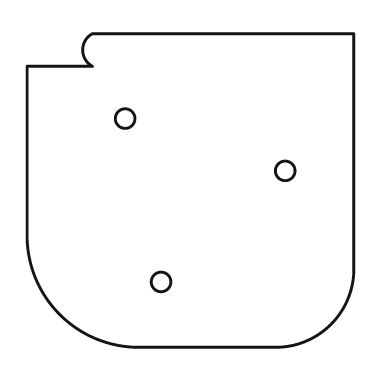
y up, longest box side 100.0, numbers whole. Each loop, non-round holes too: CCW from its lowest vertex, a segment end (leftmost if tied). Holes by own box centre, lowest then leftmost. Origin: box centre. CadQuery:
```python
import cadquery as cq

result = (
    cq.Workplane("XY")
    .moveTo(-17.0, -48.0)
    .lineTo(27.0, -48.0)
    .threePointArc((43.0, -41.0), (50.0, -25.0))
    .lineTo(50.0, 48.0)
    .lineTo(-30.0, 48.0)
    .threePointArc((-33.0, 43.0), (-30.0, 38.0))
    .lineTo(-50.0, 38.0)
    .lineTo(-50.0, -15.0)
    .threePointArc((-40.0, -38.0), (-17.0, -48.0))
    .close()
    .moveTo(-9.0, -28.0)
    .circle(3.0)
    .moveTo(29.0, 6.0)
    .circle(3.0)
    .moveTo(-20.0, 22.0)
    .circle(3.0)
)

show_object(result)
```